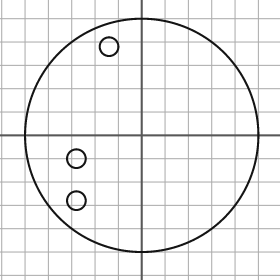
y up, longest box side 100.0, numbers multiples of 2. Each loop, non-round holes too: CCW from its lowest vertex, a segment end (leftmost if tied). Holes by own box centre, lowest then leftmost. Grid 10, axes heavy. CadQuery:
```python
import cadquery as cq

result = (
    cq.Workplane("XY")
    .moveTo(0.0, 0.0)
    .circle(50.0)
    .moveTo(-28.0, -28.0)
    .circle(4.0)
    .moveTo(-28.0, -10.0)
    .circle(4.0)
    .moveTo(-14.0, 38.0)
    .circle(4.0)
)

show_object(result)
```